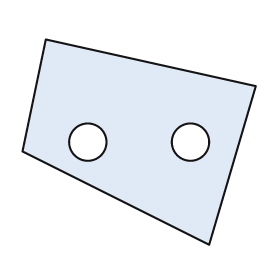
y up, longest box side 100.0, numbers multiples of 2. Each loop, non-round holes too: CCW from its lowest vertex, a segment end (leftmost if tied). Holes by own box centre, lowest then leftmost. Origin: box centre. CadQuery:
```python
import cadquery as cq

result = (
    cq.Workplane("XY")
    .moveTo(30.0, -44.0)
    .lineTo(50.0, 24.0)
    .lineTo(-40.0, 44.0)
    .lineTo(-50.0, -4.0)
    .close()
    .moveTo(-22.0, 0.0)
    .circle(8.0)
    .moveTo(22.0, 0.0)
    .circle(8.0)
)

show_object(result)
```